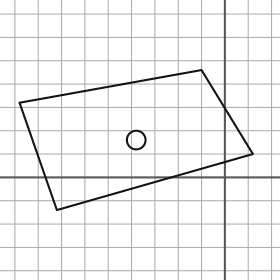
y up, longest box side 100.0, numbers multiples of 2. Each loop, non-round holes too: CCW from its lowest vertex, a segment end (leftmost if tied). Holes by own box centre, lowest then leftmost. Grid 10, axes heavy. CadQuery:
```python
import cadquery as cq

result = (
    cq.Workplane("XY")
    .moveTo(-72.0, -14.0)
    .lineTo(12.0, 10.0)
    .lineTo(-10.0, 46.0)
    .lineTo(-88.0, 32.0)
    .close()
    .moveTo(-38.0, 16.0)
    .circle(4.0)
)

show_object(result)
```